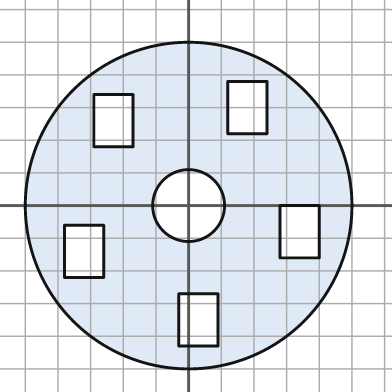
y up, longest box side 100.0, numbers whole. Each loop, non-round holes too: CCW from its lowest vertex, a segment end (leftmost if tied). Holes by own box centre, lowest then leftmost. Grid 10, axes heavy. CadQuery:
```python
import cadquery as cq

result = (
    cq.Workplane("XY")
    .moveTo(0.0, 0.0)
    .circle(50.0)
    .moveTo(-3.0, -43.0)
    .lineTo(9.0, -43.0)
    .lineTo(9.0, -27.0)
    .lineTo(-3.0, -27.0)
    .close()
    .moveTo(-38.0, -22.0)
    .lineTo(-26.0, -22.0)
    .lineTo(-26.0, -6.0)
    .lineTo(-38.0, -6.0)
    .close()
    .moveTo(28.0, -16.0)
    .lineTo(40.0, -16.0)
    .lineTo(40.0, 0.0)
    .lineTo(28.0, 0.0)
    .close()
    .moveTo(0.0, 0.0)
    .circle(11.0)
    .moveTo(-29.0, 18.0)
    .lineTo(-17.0, 18.0)
    .lineTo(-17.0, 34.0)
    .lineTo(-29.0, 34.0)
    .close()
    .moveTo(12.0, 22.0)
    .lineTo(24.0, 22.0)
    .lineTo(24.0, 38.0)
    .lineTo(12.0, 38.0)
    .close()
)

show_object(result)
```